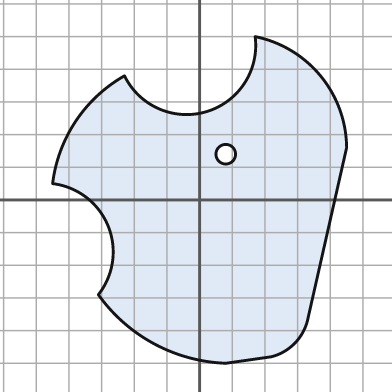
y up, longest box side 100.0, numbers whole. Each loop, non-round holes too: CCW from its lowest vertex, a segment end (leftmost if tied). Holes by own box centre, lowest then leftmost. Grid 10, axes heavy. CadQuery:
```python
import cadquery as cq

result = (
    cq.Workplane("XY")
    .moveTo(8.0, -50.0)
    .lineTo(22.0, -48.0)
    .threePointArc((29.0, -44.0), (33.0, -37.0))
    .lineTo(45.0, 16.0)
    .threePointArc((37.0, 38.0), (17.0, 50.0))
    .threePointArc((2.0, 27.0), (-23.0, 38.0))
    .threePointArc((-38.0, 24.0), (-45.0, 5.0))
    .threePointArc((-28.0, -8.0), (-31.0, -29.0))
    .threePointArc((-14.0, -44.0), (8.0, -50.0))
    .close()
    .moveTo(8.0, 14.0)
    .circle(3.0)
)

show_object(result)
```